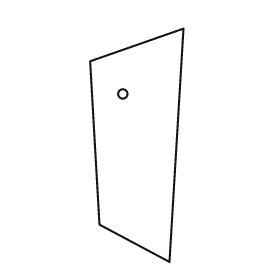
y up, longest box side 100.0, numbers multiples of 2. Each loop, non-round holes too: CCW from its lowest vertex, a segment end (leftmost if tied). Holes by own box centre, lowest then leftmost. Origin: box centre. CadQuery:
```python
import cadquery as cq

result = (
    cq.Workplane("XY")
    .moveTo(14.0, -50.0)
    .lineTo(20.0, 50.0)
    .lineTo(-20.0, 36.0)
    .lineTo(-16.0, -34.0)
    .close()
    .moveTo(-6.0, 22.0)
    .circle(2.0)
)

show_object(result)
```